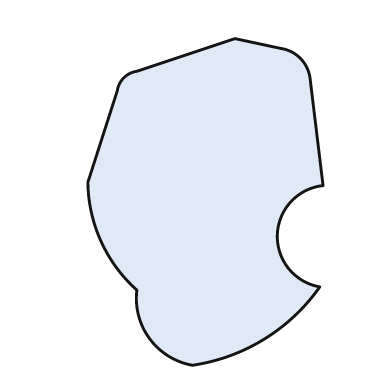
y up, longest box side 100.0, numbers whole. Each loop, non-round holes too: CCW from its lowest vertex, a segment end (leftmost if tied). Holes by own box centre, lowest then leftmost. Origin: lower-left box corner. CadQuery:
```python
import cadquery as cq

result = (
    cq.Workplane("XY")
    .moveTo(32.0, 0.0)
    .threePointArc((54.0, 8.0), (71.0, 24.0))
    .threePointArc((58.0, 40.0), (72.0, 55.0))
    .lineTo(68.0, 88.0)
    .threePointArc((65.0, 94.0), (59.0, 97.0))
    .lineTo(45.0, 100.0)
    .lineTo(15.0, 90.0)
    .threePointArc((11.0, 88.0), (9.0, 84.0))
    .lineTo(0.0, 56.0)
    .threePointArc((4.0, 38.0), (15.0, 23.0))
    .threePointArc((19.0, 8.0), (32.0, 0.0))
    .close()
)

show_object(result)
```